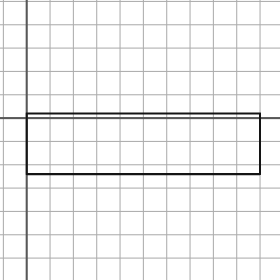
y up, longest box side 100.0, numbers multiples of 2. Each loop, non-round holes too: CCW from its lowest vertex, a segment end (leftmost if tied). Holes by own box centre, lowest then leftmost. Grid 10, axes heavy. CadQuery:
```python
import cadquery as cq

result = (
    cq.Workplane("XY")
    .moveTo(0.0, -24.0)
    .lineTo(100.0, -24.0)
    .lineTo(100.0, 2.0)
    .lineTo(0.0, 2.0)
    .close()
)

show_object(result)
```